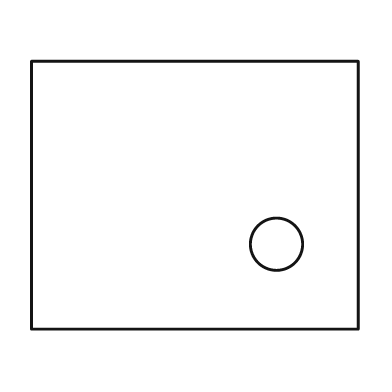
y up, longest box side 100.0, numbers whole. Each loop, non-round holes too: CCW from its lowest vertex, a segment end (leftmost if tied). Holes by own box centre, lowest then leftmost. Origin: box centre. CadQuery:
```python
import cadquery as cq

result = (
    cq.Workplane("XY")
    .moveTo(-50.0, -41.0)
    .lineTo(50.0, -41.0)
    .lineTo(50.0, 41.0)
    .lineTo(-50.0, 41.0)
    .close()
    .moveTo(25.0, -15.0)
    .circle(8.0)
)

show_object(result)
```